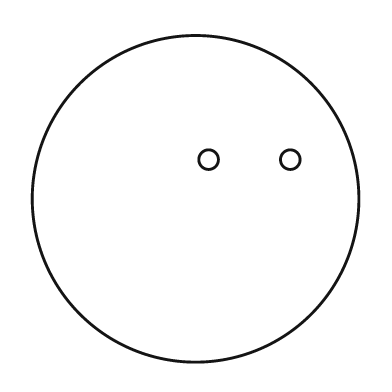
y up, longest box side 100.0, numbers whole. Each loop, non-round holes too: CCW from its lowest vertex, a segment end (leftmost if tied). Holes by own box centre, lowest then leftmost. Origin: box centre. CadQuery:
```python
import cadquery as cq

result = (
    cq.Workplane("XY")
    .moveTo(0.0, 0.0)
    .circle(50.0)
    .moveTo(4.0, 12.0)
    .circle(3.0)
    .moveTo(29.0, 12.0)
    .circle(3.0)
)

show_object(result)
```